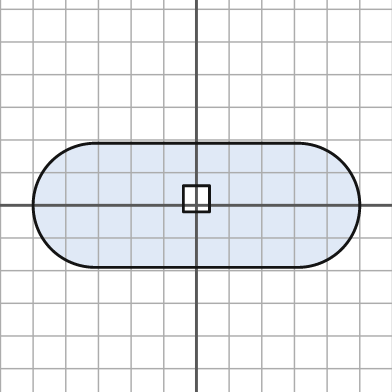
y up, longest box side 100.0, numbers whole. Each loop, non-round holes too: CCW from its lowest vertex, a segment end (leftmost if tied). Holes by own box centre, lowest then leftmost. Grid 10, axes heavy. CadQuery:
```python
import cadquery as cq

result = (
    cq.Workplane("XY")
    .moveTo(-31.0, -19.0)
    .lineTo(31.0, -19.0)
    .threePointArc((50.0, 0.0), (31.0, 19.0))
    .lineTo(-31.0, 19.0)
    .threePointArc((-50.0, 0.0), (-31.0, -19.0))
    .close()
    .moveTo(-4.0, -2.0)
    .lineTo(4.0, -2.0)
    .lineTo(4.0, 6.0)
    .lineTo(-4.0, 6.0)
    .close()
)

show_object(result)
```